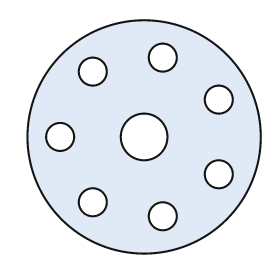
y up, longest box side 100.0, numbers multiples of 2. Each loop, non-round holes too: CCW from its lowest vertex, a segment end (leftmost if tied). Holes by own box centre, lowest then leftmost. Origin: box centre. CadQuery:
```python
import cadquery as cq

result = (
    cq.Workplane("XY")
    .moveTo(0.0, 0.0)
    .circle(50.0)
    .moveTo(8.0, -34.0)
    .circle(6.0)
    .moveTo(-22.0, -28.0)
    .circle(6.0)
    .moveTo(32.0, -16.0)
    .circle(6.0)
    .moveTo(-36.0, 0.0)
    .circle(6.0)
    .moveTo(0.0, 0.0)
    .circle(10.0)
    .moveTo(32.0, 16.0)
    .circle(6.0)
    .moveTo(-22.0, 28.0)
    .circle(6.0)
    .moveTo(8.0, 34.0)
    .circle(6.0)
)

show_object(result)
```